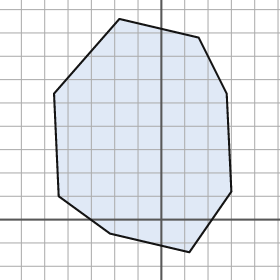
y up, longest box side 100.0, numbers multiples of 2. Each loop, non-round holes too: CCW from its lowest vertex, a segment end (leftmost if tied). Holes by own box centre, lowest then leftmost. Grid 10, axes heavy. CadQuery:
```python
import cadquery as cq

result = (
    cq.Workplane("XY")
    .moveTo(12.0, -14.0)
    .lineTo(30.0, 12.0)
    .lineTo(28.0, 54.0)
    .lineTo(16.0, 78.0)
    .lineTo(-18.0, 86.0)
    .lineTo(-46.0, 54.0)
    .lineTo(-44.0, 10.0)
    .lineTo(-22.0, -6.0)
    .close()
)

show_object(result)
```